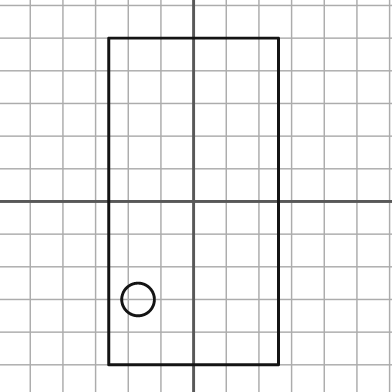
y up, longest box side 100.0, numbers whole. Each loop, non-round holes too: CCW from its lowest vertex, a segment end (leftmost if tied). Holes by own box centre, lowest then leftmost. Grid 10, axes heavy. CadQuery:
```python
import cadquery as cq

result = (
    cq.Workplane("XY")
    .moveTo(-26.0, -50.0)
    .lineTo(26.0, -50.0)
    .lineTo(26.0, 50.0)
    .lineTo(-26.0, 50.0)
    .close()
    .moveTo(-17.0, -30.0)
    .circle(5.0)
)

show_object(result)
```